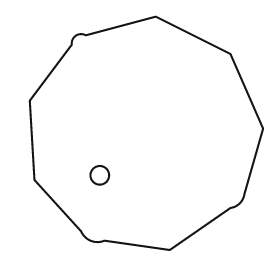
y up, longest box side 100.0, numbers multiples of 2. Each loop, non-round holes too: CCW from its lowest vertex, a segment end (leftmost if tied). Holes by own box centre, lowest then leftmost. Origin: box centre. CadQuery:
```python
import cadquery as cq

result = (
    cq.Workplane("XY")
    .moveTo(10.0, -50.0)
    .lineTo(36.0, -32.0)
    .threePointArc((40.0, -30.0), (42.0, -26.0))
    .lineTo(50.0, 2.0)
    .lineTo(36.0, 34.0)
    .lineTo(4.0, 50.0)
    .lineTo(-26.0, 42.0)
    .threePointArc((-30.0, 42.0), (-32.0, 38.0))
    .lineTo(-50.0, 14.0)
    .lineTo(-48.0, -20.0)
    .lineTo(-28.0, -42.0)
    .threePointArc((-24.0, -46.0), (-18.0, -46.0))
    .close()
    .moveTo(-20.0, -18.0)
    .circle(4.0)
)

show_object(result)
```